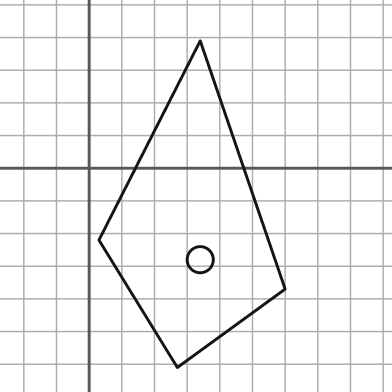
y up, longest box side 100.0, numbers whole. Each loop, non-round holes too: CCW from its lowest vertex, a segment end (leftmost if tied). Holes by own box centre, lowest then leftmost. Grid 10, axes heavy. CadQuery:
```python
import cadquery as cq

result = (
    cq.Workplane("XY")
    .moveTo(27.0, -61.0)
    .lineTo(60.0, -37.0)
    .lineTo(34.0, 39.0)
    .lineTo(3.0, -22.0)
    .close()
    .moveTo(34.0, -28.0)
    .circle(4.0)
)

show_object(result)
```